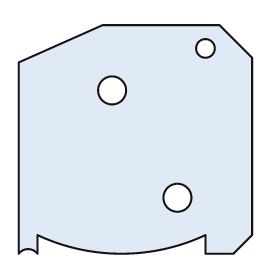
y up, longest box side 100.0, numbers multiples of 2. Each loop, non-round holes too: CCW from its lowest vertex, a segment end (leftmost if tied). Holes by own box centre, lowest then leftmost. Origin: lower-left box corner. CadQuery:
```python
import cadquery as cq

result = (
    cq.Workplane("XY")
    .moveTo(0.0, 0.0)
    .threePointArc((4.0, 2.0), (8.0, 0.0))
    .lineTo(8.0, 8.0)
    .threePointArc((44.0, 0.0), (80.0, 8.0))
    .lineTo(80.0, 0.0)
    .lineTo(92.0, 0.0)
    .lineTo(100.0, 8.0)
    .lineTo(100.0, 84.0)
    .lineTo(86.0, 98.0)
    .lineTo(36.0, 98.0)
    .lineTo(0.0, 82.0)
    .close()
    .moveTo(68.0, 24.0)
    .circle(6.0)
    .moveTo(40.0, 70.0)
    .circle(6.0)
    .moveTo(80.0, 88.0)
    .circle(4.0)
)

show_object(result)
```